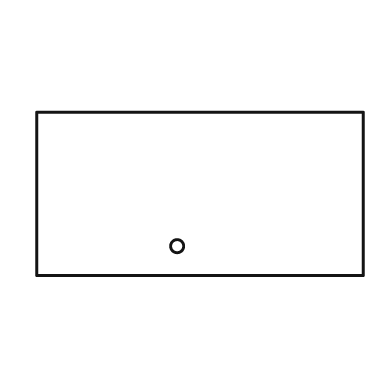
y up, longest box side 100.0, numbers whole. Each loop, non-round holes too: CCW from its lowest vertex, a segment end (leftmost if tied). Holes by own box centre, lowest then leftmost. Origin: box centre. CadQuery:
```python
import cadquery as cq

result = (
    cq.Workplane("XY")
    .moveTo(-50.0, -25.0)
    .lineTo(50.0, -25.0)
    .lineTo(50.0, 25.0)
    .lineTo(-50.0, 25.0)
    .close()
    .moveTo(-7.0, -16.0)
    .circle(2.0)
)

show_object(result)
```